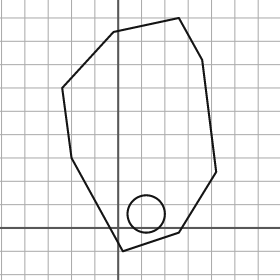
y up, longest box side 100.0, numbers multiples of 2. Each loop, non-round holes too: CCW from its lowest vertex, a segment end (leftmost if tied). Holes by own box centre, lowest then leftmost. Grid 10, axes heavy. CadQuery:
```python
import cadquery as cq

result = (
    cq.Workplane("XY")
    .moveTo(2.0, -10.0)
    .lineTo(26.0, -2.0)
    .lineTo(42.0, 24.0)
    .lineTo(36.0, 72.0)
    .lineTo(26.0, 90.0)
    .lineTo(-2.0, 84.0)
    .lineTo(-24.0, 60.0)
    .lineTo(-20.0, 30.0)
    .close()
    .moveTo(12.0, 6.0)
    .circle(8.0)
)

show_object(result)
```